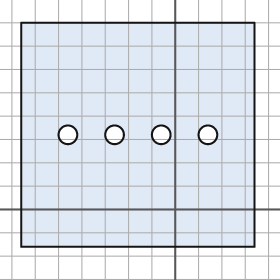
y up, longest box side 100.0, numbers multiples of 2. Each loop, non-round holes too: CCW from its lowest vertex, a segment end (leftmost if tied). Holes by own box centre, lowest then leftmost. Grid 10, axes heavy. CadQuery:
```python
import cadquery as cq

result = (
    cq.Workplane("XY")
    .moveTo(-66.0, -16.0)
    .lineTo(34.0, -16.0)
    .lineTo(34.0, 80.0)
    .lineTo(-66.0, 80.0)
    .close()
    .moveTo(-46.0, 32.0)
    .circle(4.0)
    .moveTo(-26.0, 32.0)
    .circle(4.0)
    .moveTo(-6.0, 32.0)
    .circle(4.0)
    .moveTo(14.0, 32.0)
    .circle(4.0)
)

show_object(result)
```